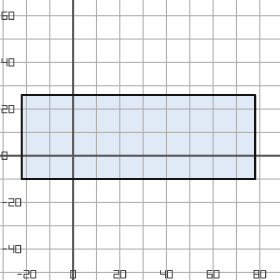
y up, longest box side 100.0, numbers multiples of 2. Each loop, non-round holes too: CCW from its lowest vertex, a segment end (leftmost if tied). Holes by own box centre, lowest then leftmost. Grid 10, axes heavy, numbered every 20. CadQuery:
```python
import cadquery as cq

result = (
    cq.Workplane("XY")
    .moveTo(-22.0, -10.0)
    .lineTo(78.0, -10.0)
    .lineTo(78.0, 26.0)
    .lineTo(-22.0, 26.0)
    .close()
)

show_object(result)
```